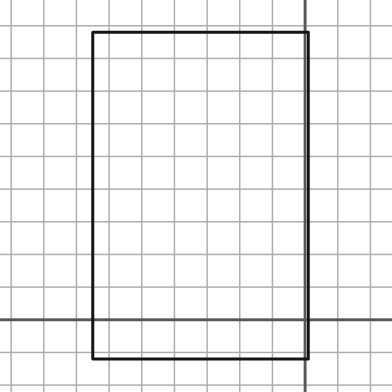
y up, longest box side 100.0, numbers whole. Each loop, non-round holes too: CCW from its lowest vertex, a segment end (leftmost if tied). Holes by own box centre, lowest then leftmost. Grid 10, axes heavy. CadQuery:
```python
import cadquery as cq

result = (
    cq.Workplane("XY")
    .moveTo(-65.0, -12.0)
    .lineTo(1.0, -12.0)
    .lineTo(1.0, 88.0)
    .lineTo(-65.0, 88.0)
    .close()
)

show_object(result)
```